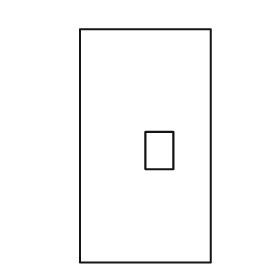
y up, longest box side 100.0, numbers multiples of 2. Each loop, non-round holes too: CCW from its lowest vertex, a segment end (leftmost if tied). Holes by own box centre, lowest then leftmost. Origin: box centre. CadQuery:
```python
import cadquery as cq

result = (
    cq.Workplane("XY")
    .moveTo(-28.0, -50.0)
    .lineTo(28.0, -50.0)
    .lineTo(28.0, 50.0)
    .lineTo(-28.0, 50.0)
    .close()
    .moveTo(0.0, -10.0)
    .lineTo(12.0, -10.0)
    .lineTo(12.0, 6.0)
    .lineTo(0.0, 6.0)
    .close()
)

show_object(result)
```